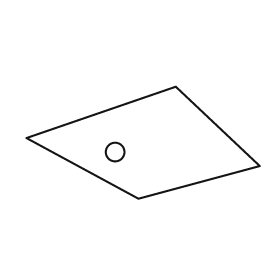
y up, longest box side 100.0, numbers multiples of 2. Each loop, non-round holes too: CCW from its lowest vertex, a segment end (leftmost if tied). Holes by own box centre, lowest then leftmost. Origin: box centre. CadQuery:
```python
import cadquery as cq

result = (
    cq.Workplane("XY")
    .moveTo(-2.0, -24.0)
    .lineTo(50.0, -10.0)
    .lineTo(14.0, 24.0)
    .lineTo(-50.0, 2.0)
    .close()
    .moveTo(-12.0, -4.0)
    .circle(4.0)
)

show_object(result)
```